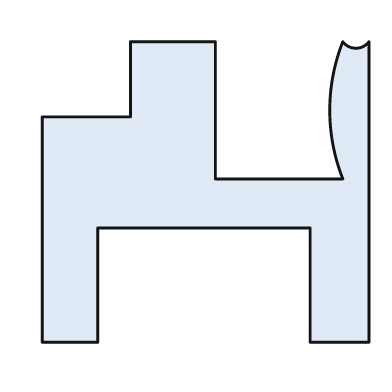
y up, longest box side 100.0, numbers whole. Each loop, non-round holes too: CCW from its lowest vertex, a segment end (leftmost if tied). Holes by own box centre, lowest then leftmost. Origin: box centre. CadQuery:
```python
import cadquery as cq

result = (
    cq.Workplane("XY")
    .moveTo(-50.0, -46.0)
    .lineTo(-33.0, -46.0)
    .lineTo(-33.0, -11.0)
    .lineTo(32.0, -11.0)
    .lineTo(32.0, -46.0)
    .lineTo(50.0, -46.0)
    .lineTo(50.0, 46.0)
    .threePointArc((46.0, 44.0), (42.0, 46.0))
    .threePointArc((38.0, 25.0), (42.0, 4.0))
    .lineTo(3.0, 4.0)
    .lineTo(3.0, 46.0)
    .lineTo(-23.0, 46.0)
    .lineTo(-23.0, 23.0)
    .lineTo(-50.0, 23.0)
    .close()
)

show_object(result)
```